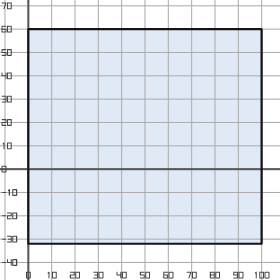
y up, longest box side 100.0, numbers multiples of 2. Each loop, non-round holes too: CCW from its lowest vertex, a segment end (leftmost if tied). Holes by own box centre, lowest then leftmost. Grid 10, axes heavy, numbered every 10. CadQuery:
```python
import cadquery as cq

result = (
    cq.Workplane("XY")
    .moveTo(0.0, -32.0)
    .lineTo(100.0, -32.0)
    .lineTo(100.0, 60.0)
    .lineTo(0.0, 60.0)
    .close()
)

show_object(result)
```